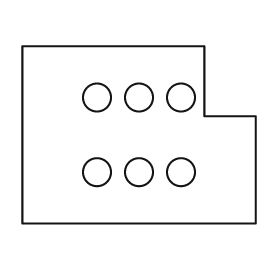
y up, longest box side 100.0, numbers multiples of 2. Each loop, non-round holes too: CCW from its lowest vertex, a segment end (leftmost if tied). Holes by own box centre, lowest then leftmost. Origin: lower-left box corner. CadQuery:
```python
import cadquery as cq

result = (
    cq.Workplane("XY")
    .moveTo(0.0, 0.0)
    .lineTo(100.0, 0.0)
    .lineTo(100.0, 46.0)
    .lineTo(78.0, 46.0)
    .lineTo(78.0, 76.0)
    .lineTo(0.0, 76.0)
    .close()
    .moveTo(32.0, 22.0)
    .circle(6.0)
    .moveTo(50.0, 22.0)
    .circle(6.0)
    .moveTo(68.0, 22.0)
    .circle(6.0)
    .moveTo(32.0, 54.0)
    .circle(6.0)
    .moveTo(50.0, 54.0)
    .circle(6.0)
    .moveTo(68.0, 54.0)
    .circle(6.0)
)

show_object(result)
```